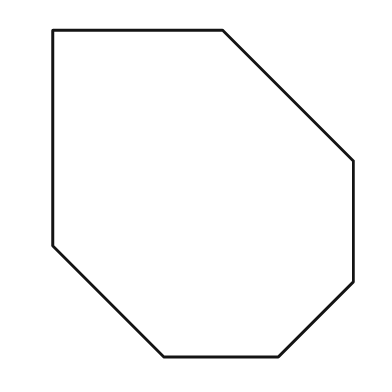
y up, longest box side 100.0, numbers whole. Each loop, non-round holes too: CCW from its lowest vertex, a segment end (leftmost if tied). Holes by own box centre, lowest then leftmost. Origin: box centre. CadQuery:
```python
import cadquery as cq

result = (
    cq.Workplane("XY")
    .moveTo(-12.0, -50.0)
    .lineTo(23.0, -50.0)
    .lineTo(46.0, -27.0)
    .lineTo(46.0, 10.0)
    .lineTo(6.0, 50.0)
    .lineTo(-46.0, 50.0)
    .lineTo(-46.0, -16.0)
    .close()
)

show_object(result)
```